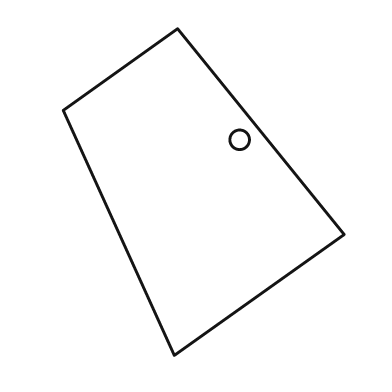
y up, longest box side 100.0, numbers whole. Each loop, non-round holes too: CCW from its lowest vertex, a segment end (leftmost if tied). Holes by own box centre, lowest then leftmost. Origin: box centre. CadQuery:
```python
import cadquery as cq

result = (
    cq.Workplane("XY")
    .moveTo(-9.0, -50.0)
    .lineTo(43.0, -13.0)
    .lineTo(-8.0, 50.0)
    .lineTo(-43.0, 25.0)
    .close()
    .moveTo(11.0, 16.0)
    .circle(3.0)
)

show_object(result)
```